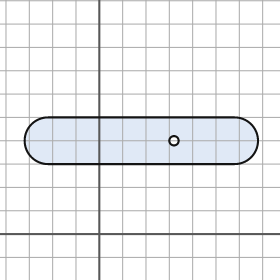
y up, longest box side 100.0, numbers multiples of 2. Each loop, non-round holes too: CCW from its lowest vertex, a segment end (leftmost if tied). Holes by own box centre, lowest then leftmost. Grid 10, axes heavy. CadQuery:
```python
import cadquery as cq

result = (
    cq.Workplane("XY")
    .moveTo(-22.0, 30.0)
    .lineTo(58.0, 30.0)
    .threePointArc((68.0, 40.0), (58.0, 50.0))
    .lineTo(-22.0, 50.0)
    .threePointArc((-32.0, 40.0), (-22.0, 30.0))
    .close()
    .moveTo(32.0, 40.0)
    .circle(2.0)
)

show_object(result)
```